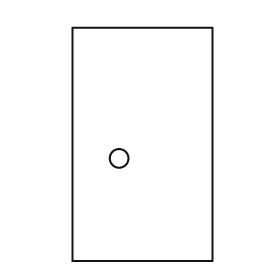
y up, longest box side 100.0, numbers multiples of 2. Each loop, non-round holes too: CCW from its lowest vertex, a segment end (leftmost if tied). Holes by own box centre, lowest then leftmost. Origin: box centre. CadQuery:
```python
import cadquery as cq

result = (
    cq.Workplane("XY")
    .moveTo(-30.0, -50.0)
    .lineTo(30.0, -50.0)
    .lineTo(30.0, 50.0)
    .lineTo(-30.0, 50.0)
    .close()
    .moveTo(-10.0, -6.0)
    .circle(4.0)
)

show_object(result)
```